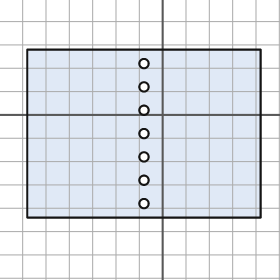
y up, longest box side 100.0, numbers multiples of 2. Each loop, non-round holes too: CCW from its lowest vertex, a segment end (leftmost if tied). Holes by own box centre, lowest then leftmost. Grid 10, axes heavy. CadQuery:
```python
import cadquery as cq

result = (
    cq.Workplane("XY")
    .moveTo(-58.0, -44.0)
    .lineTo(42.0, -44.0)
    .lineTo(42.0, 28.0)
    .lineTo(-58.0, 28.0)
    .close()
    .moveTo(-8.0, -38.0)
    .circle(2.0)
    .moveTo(-8.0, -28.0)
    .circle(2.0)
    .moveTo(-8.0, -18.0)
    .circle(2.0)
    .moveTo(-8.0, -8.0)
    .circle(2.0)
    .moveTo(-8.0, 2.0)
    .circle(2.0)
    .moveTo(-8.0, 12.0)
    .circle(2.0)
    .moveTo(-8.0, 22.0)
    .circle(2.0)
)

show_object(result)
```